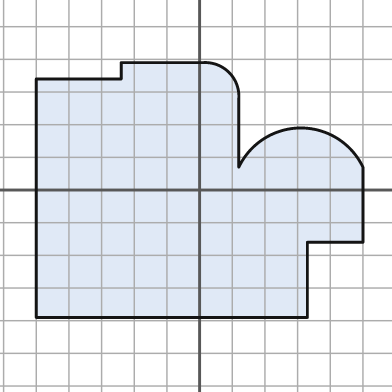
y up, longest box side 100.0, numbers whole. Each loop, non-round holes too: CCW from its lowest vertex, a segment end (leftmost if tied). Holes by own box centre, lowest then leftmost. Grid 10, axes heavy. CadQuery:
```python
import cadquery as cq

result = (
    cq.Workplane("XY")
    .moveTo(-50.0, -39.0)
    .lineTo(33.0, -39.0)
    .lineTo(33.0, -16.0)
    .lineTo(50.0, -16.0)
    .lineTo(50.0, 7.0)
    .threePointArc((31.0, 19.0), (12.0, 7.0))
    .lineTo(12.0, 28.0)
    .threePointArc((9.0, 36.0), (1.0, 39.0))
    .lineTo(-24.0, 39.0)
    .lineTo(-24.0, 34.0)
    .lineTo(-50.0, 34.0)
    .close()
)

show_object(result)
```